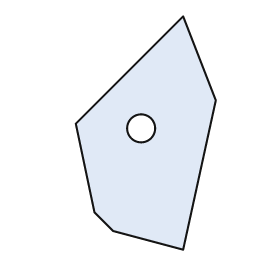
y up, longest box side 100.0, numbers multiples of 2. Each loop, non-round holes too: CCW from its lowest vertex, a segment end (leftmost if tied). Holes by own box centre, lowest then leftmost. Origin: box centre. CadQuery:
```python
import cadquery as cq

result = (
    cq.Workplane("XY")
    .moveTo(16.0, -50.0)
    .lineTo(30.0, 14.0)
    .lineTo(16.0, 50.0)
    .lineTo(-30.0, 4.0)
    .lineTo(-22.0, -34.0)
    .lineTo(-14.0, -42.0)
    .close()
    .moveTo(-2.0, 2.0)
    .circle(6.0)
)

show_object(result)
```